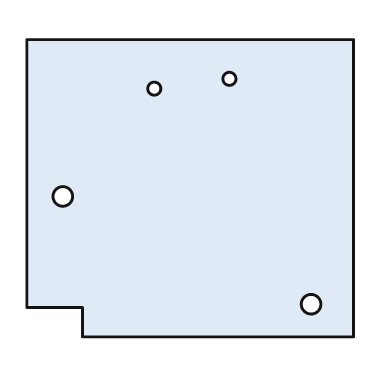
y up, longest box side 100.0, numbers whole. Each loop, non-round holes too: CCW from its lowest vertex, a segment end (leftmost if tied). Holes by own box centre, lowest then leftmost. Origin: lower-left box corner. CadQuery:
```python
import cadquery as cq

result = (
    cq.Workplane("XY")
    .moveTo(17.0, 0.0)
    .lineTo(100.0, 0.0)
    .lineTo(100.0, 91.0)
    .lineTo(0.0, 91.0)
    .lineTo(0.0, 9.0)
    .lineTo(17.0, 9.0)
    .close()
    .moveTo(87.0, 10.0)
    .circle(3.0)
    .moveTo(11.0, 43.0)
    .circle(3.0)
    .moveTo(39.0, 76.0)
    .circle(2.0)
    .moveTo(62.0, 79.0)
    .circle(2.0)
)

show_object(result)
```